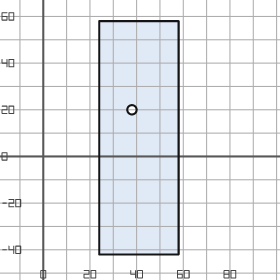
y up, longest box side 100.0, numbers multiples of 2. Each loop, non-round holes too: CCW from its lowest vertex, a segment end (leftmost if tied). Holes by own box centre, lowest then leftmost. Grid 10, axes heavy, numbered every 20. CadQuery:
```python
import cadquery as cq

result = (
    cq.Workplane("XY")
    .moveTo(24.0, -42.0)
    .lineTo(58.0, -42.0)
    .lineTo(58.0, 58.0)
    .lineTo(24.0, 58.0)
    .close()
    .moveTo(38.0, 20.0)
    .circle(2.0)
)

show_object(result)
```